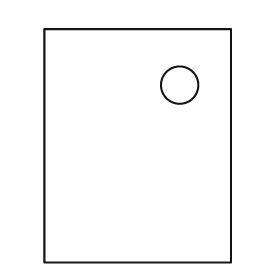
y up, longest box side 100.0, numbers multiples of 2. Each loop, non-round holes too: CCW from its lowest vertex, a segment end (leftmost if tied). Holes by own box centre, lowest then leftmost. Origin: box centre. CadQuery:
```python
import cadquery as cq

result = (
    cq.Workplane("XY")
    .moveTo(-40.0, -50.0)
    .lineTo(40.0, -50.0)
    .lineTo(40.0, 50.0)
    .lineTo(-40.0, 50.0)
    .close()
    .moveTo(18.0, 26.0)
    .circle(8.0)
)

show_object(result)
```